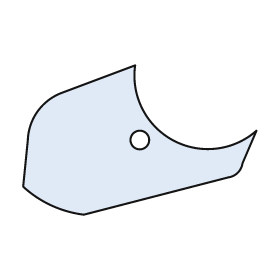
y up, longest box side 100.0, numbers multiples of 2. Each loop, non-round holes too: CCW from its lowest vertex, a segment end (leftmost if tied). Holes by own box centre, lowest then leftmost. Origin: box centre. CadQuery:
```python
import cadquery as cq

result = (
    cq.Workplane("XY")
    .moveTo(-24.0, -32.0)
    .lineTo(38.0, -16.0)
    .threePointArc((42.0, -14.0), (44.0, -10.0))
    .lineTo(50.0, 4.0)
    .threePointArc((14.0, 0.0), (-2.0, 32.0))
    .lineTo(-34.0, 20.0)
    .threePointArc((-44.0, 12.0), (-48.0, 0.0))
    .lineTo(-50.0, -20.0)
    .threePointArc((-38.0, -28.0), (-24.0, -32.0))
    .close()
    .moveTo(0.0, 0.0)
    .circle(4.0)
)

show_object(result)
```